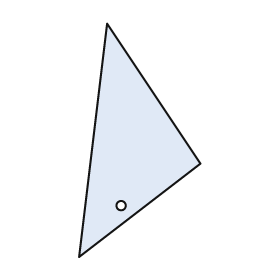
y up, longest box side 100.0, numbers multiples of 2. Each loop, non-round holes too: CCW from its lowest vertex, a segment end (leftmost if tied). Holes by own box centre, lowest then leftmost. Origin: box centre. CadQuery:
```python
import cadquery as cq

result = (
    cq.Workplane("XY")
    .moveTo(-26.0, -50.0)
    .lineTo(26.0, -10.0)
    .lineTo(-14.0, 50.0)
    .close()
    .moveTo(-8.0, -28.0)
    .circle(2.0)
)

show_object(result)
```